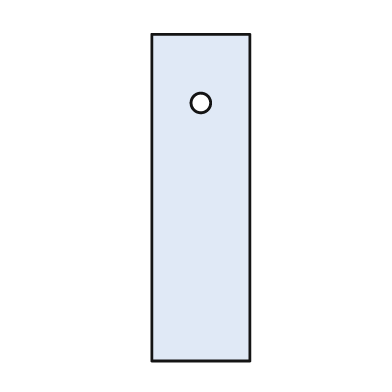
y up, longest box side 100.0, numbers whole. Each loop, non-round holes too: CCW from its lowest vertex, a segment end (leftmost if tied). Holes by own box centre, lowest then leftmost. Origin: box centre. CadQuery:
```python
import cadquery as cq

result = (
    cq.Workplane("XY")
    .moveTo(-15.0, -50.0)
    .lineTo(15.0, -50.0)
    .lineTo(15.0, 50.0)
    .lineTo(-15.0, 50.0)
    .close()
    .moveTo(0.0, 29.0)
    .circle(3.0)
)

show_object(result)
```